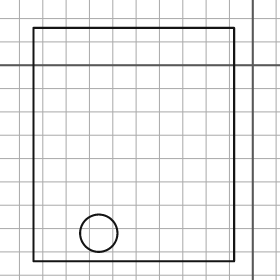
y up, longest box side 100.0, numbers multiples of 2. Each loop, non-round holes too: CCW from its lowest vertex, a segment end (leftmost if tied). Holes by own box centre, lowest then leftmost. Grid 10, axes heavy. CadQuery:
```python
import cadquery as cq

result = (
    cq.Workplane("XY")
    .moveTo(-94.0, -84.0)
    .lineTo(-8.0, -84.0)
    .lineTo(-8.0, 16.0)
    .lineTo(-94.0, 16.0)
    .close()
    .moveTo(-66.0, -72.0)
    .circle(8.0)
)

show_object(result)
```